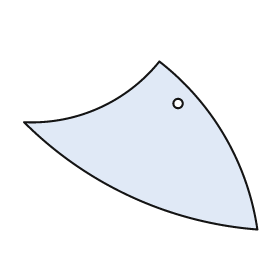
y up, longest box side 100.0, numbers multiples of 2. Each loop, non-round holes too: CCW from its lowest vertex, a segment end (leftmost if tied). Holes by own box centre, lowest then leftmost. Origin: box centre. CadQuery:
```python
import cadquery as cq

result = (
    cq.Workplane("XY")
    .moveTo(50.0, -36.0)
    .threePointArc((36.0, 4.0), (8.0, 36.0))
    .threePointArc((-18.0, 16.0), (-50.0, 10.0))
    .threePointArc((-4.0, -22.0), (50.0, -36.0))
    .close()
    .moveTo(16.0, 18.0)
    .circle(2.0)
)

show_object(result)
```